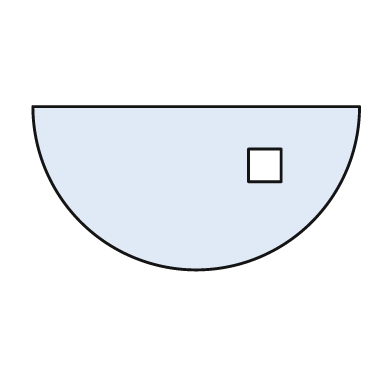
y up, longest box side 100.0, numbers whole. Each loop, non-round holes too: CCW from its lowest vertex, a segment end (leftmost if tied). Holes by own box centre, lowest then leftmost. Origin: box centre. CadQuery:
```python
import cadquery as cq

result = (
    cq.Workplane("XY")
    .moveTo(-50.0, 25.0)
    .threePointArc((0.0, -25.0), (50.0, 25.0))
    .close()
    .moveTo(16.0, 2.0)
    .lineTo(26.0, 2.0)
    .lineTo(26.0, 12.0)
    .lineTo(16.0, 12.0)
    .close()
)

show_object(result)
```